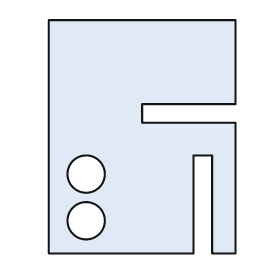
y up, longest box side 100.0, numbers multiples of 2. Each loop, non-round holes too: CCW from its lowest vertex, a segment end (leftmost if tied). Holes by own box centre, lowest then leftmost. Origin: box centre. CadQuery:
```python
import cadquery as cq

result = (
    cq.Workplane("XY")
    .moveTo(-40.0, -50.0)
    .lineTo(22.0, -50.0)
    .lineTo(22.0, -8.0)
    .lineTo(30.0, -8.0)
    .lineTo(30.0, -50.0)
    .lineTo(40.0, -50.0)
    .lineTo(40.0, 6.0)
    .lineTo(0.0, 6.0)
    .lineTo(0.0, 14.0)
    .lineTo(40.0, 14.0)
    .lineTo(40.0, 50.0)
    .lineTo(-40.0, 50.0)
    .close()
    .moveTo(-24.0, -36.0)
    .circle(8.0)
    .moveTo(-24.0, -16.0)
    .circle(8.0)
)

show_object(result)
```